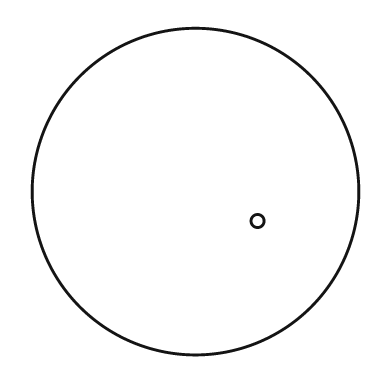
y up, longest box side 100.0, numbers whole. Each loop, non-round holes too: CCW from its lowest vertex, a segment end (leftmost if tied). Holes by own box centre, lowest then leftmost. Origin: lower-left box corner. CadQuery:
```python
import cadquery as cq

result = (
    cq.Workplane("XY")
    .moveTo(50.0, 50.0)
    .circle(50.0)
    .moveTo(69.0, 41.0)
    .circle(2.0)
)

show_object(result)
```